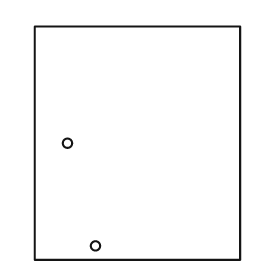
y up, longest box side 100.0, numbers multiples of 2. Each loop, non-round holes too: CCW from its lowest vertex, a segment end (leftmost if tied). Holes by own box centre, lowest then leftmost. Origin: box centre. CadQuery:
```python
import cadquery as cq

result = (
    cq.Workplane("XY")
    .moveTo(-44.0, -50.0)
    .lineTo(44.0, -50.0)
    .lineTo(44.0, 50.0)
    .lineTo(-44.0, 50.0)
    .close()
    .moveTo(-18.0, -44.0)
    .circle(2.0)
    .moveTo(-30.0, 0.0)
    .circle(2.0)
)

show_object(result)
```